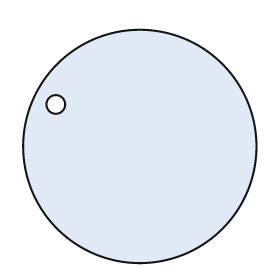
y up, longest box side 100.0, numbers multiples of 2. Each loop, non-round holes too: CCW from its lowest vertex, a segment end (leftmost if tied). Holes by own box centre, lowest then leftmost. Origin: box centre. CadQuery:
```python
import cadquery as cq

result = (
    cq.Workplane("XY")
    .moveTo(0.0, 0.0)
    .circle(50.0)
    .moveTo(-36.0, 18.0)
    .circle(4.0)
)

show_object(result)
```